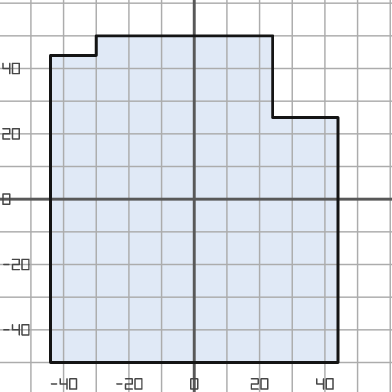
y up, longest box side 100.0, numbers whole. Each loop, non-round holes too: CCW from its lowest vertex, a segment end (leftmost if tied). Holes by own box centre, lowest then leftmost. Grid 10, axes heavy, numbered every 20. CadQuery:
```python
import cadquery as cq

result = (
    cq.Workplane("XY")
    .moveTo(-44.0, -50.0)
    .lineTo(44.0, -50.0)
    .lineTo(44.0, 25.0)
    .lineTo(24.0, 25.0)
    .lineTo(24.0, 50.0)
    .lineTo(-30.0, 50.0)
    .lineTo(-30.0, 44.0)
    .lineTo(-44.0, 44.0)
    .close()
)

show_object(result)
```